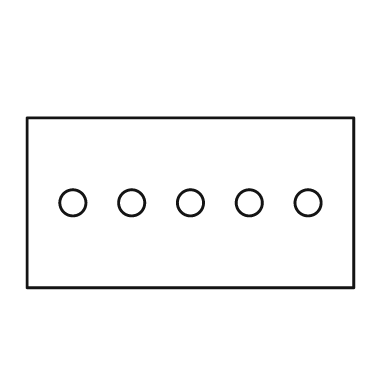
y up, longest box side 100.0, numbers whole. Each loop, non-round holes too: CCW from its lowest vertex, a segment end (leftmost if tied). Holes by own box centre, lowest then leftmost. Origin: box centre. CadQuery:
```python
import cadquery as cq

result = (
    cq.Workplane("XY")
    .moveTo(-50.0, -26.0)
    .lineTo(50.0, -26.0)
    .lineTo(50.0, 26.0)
    .lineTo(-50.0, 26.0)
    .close()
    .moveTo(-36.0, 0.0)
    .circle(4.0)
    .moveTo(-18.0, 0.0)
    .circle(4.0)
    .moveTo(0.0, 0.0)
    .circle(4.0)
    .moveTo(18.0, 0.0)
    .circle(4.0)
    .moveTo(36.0, 0.0)
    .circle(4.0)
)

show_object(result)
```